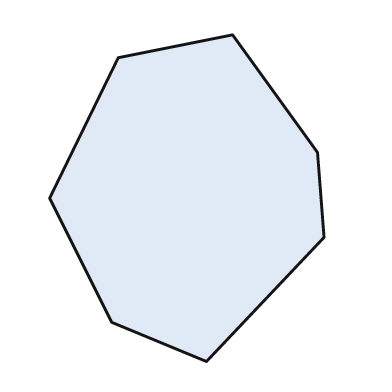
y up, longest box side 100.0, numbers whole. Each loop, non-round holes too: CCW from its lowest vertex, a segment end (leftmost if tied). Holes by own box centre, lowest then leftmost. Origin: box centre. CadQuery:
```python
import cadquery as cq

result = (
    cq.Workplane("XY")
    .moveTo(6.0, -50.0)
    .lineTo(42.0, -12.0)
    .lineTo(40.0, 14.0)
    .lineTo(14.0, 50.0)
    .lineTo(-21.0, 43.0)
    .lineTo(-42.0, 0.0)
    .lineTo(-23.0, -38.0)
    .close()
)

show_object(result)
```